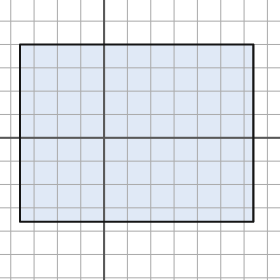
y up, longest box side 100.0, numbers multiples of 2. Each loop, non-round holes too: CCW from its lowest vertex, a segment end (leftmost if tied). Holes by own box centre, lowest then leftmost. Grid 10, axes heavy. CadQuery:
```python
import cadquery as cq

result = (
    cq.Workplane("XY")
    .moveTo(-36.0, -36.0)
    .lineTo(64.0, -36.0)
    .lineTo(64.0, 40.0)
    .lineTo(-36.0, 40.0)
    .close()
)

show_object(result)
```